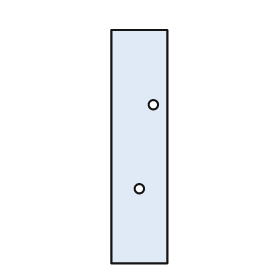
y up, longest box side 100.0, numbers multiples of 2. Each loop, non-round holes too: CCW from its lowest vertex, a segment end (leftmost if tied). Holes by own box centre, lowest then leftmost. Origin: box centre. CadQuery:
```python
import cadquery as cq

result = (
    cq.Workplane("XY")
    .moveTo(-12.0, -50.0)
    .lineTo(12.0, -50.0)
    .lineTo(12.0, 50.0)
    .lineTo(-12.0, 50.0)
    .close()
    .moveTo(0.0, -18.0)
    .circle(2.0)
    .moveTo(6.0, 18.0)
    .circle(2.0)
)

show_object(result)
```